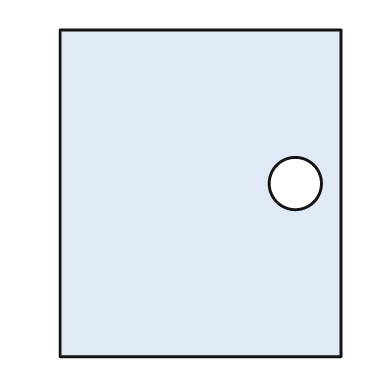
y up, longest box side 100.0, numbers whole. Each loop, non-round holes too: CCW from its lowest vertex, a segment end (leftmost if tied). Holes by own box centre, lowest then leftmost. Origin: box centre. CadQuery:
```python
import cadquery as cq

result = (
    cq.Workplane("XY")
    .moveTo(-43.0, -50.0)
    .lineTo(43.0, -50.0)
    .lineTo(43.0, 50.0)
    .lineTo(-43.0, 50.0)
    .close()
    .moveTo(29.0, 3.0)
    .circle(8.0)
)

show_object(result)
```